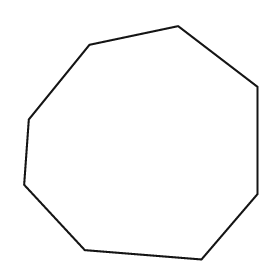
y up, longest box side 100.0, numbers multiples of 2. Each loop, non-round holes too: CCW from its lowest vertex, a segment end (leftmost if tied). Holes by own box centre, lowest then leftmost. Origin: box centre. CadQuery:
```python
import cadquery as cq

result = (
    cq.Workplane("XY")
    .moveTo(26.0, -50.0)
    .lineTo(50.0, -22.0)
    .lineTo(50.0, 24.0)
    .lineTo(16.0, 50.0)
    .lineTo(-22.0, 42.0)
    .lineTo(-48.0, 10.0)
    .lineTo(-50.0, -18.0)
    .lineTo(-24.0, -46.0)
    .close()
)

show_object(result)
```